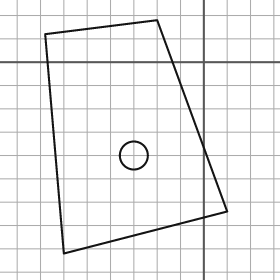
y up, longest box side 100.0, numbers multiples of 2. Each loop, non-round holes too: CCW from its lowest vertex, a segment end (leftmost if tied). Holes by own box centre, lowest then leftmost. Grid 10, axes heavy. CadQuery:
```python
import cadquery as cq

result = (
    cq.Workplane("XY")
    .moveTo(-60.0, -82.0)
    .lineTo(10.0, -64.0)
    .lineTo(-20.0, 18.0)
    .lineTo(-68.0, 12.0)
    .close()
    .moveTo(-30.0, -40.0)
    .circle(6.0)
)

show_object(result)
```